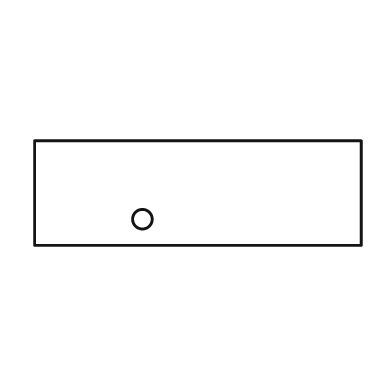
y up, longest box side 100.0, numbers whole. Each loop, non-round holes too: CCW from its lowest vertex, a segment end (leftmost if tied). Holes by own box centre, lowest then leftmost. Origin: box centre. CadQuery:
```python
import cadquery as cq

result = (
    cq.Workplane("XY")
    .moveTo(-50.0, -16.0)
    .lineTo(50.0, -16.0)
    .lineTo(50.0, 16.0)
    .lineTo(-50.0, 16.0)
    .close()
    .moveTo(-17.0, -8.0)
    .circle(3.0)
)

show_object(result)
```